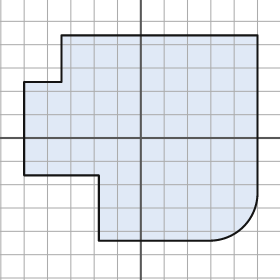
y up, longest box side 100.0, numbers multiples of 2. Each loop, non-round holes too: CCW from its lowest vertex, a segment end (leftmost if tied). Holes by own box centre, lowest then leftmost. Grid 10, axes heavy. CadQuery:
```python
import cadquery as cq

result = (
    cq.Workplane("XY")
    .moveTo(-18.0, -44.0)
    .lineTo(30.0, -44.0)
    .threePointArc((44.0, -38.0), (50.0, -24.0))
    .lineTo(50.0, 44.0)
    .lineTo(-34.0, 44.0)
    .lineTo(-34.0, 24.0)
    .lineTo(-50.0, 24.0)
    .lineTo(-50.0, -16.0)
    .lineTo(-18.0, -16.0)
    .close()
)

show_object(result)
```